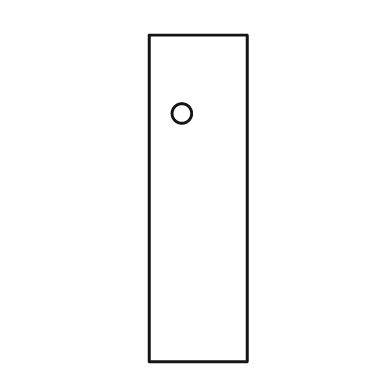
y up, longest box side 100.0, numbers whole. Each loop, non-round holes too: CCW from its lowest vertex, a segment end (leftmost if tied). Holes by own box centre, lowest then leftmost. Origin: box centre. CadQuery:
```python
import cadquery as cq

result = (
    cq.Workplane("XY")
    .moveTo(-15.0, -50.0)
    .lineTo(15.0, -50.0)
    .lineTo(15.0, 50.0)
    .lineTo(-15.0, 50.0)
    .close()
    .moveTo(-5.0, 26.0)
    .circle(3.0)
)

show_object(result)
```